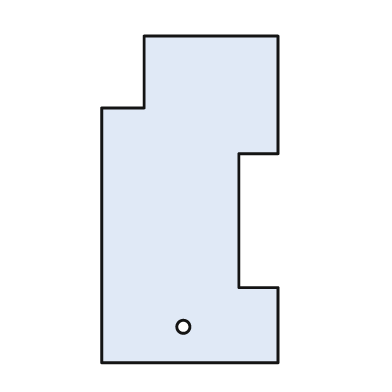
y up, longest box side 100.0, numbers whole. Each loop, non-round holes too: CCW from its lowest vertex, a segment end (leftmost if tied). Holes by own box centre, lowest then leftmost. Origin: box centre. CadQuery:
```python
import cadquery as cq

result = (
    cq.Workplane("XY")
    .moveTo(-27.0, -50.0)
    .lineTo(27.0, -50.0)
    .lineTo(27.0, -27.0)
    .lineTo(15.0, -27.0)
    .lineTo(15.0, 14.0)
    .lineTo(27.0, 14.0)
    .lineTo(27.0, 50.0)
    .lineTo(-14.0, 50.0)
    .lineTo(-14.0, 28.0)
    .lineTo(-27.0, 28.0)
    .close()
    .moveTo(-2.0, -39.0)
    .circle(2.0)
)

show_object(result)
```